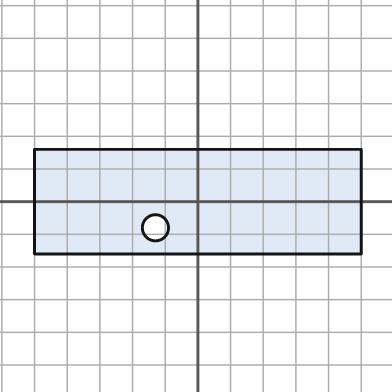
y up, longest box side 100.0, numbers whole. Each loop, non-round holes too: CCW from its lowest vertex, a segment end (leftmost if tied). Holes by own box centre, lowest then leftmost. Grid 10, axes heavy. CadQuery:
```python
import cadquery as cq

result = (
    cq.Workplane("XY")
    .moveTo(-50.0, -16.0)
    .lineTo(50.0, -16.0)
    .lineTo(50.0, 16.0)
    .lineTo(-50.0, 16.0)
    .close()
    .moveTo(-13.0, -8.0)
    .circle(4.0)
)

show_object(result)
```